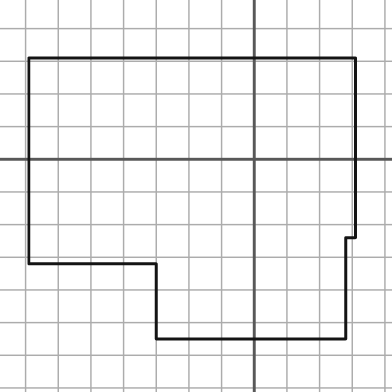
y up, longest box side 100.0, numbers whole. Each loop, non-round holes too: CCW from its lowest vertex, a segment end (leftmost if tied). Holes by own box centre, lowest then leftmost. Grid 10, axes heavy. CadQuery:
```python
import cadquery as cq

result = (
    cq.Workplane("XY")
    .moveTo(-30.0, -55.0)
    .lineTo(28.0, -55.0)
    .lineTo(28.0, -24.0)
    .lineTo(31.0, -24.0)
    .lineTo(31.0, 31.0)
    .lineTo(-69.0, 31.0)
    .lineTo(-69.0, -32.0)
    .lineTo(-30.0, -32.0)
    .close()
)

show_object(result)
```